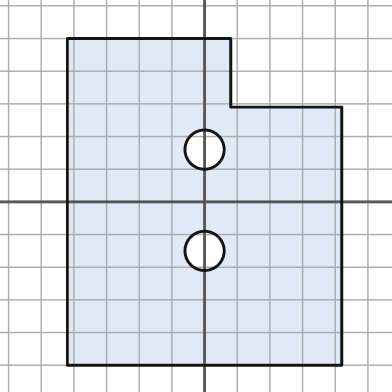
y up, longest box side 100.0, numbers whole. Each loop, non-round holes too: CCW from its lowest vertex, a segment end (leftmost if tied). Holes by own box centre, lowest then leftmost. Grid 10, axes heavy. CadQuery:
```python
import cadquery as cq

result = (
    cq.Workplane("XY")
    .moveTo(-42.0, -50.0)
    .lineTo(42.0, -50.0)
    .lineTo(42.0, 29.0)
    .lineTo(8.0, 29.0)
    .lineTo(8.0, 50.0)
    .lineTo(-42.0, 50.0)
    .close()
    .moveTo(0.0, -15.0)
    .circle(6.0)
    .moveTo(0.0, 16.0)
    .circle(6.0)
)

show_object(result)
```